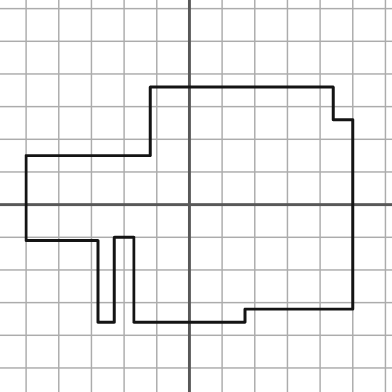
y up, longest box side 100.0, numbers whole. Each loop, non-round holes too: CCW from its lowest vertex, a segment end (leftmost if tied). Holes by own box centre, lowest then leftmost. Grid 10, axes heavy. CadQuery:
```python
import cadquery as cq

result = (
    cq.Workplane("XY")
    .moveTo(-28.0, -36.0)
    .lineTo(-23.0, -36.0)
    .lineTo(-23.0, -10.0)
    .lineTo(-17.0, -10.0)
    .lineTo(-17.0, -36.0)
    .lineTo(17.0, -36.0)
    .lineTo(17.0, -32.0)
    .lineTo(50.0, -32.0)
    .lineTo(50.0, 26.0)
    .lineTo(44.0, 26.0)
    .lineTo(44.0, 36.0)
    .lineTo(-12.0, 36.0)
    .lineTo(-12.0, 15.0)
    .lineTo(-50.0, 15.0)
    .lineTo(-50.0, -11.0)
    .lineTo(-28.0, -11.0)
    .close()
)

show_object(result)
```